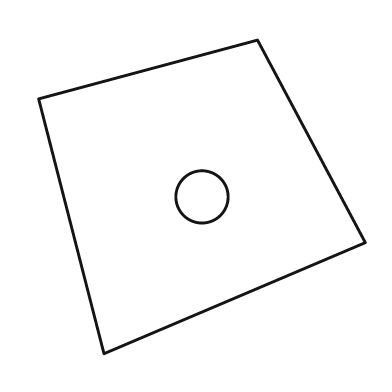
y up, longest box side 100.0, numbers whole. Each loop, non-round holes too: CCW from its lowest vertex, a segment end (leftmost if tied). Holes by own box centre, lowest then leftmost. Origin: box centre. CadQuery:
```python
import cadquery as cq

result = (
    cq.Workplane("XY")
    .moveTo(-30.0, -48.0)
    .lineTo(50.0, -14.0)
    .lineTo(17.0, 48.0)
    .lineTo(-50.0, 30.0)
    .close()
    .moveTo(0.0, 0.0)
    .circle(8.0)
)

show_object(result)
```